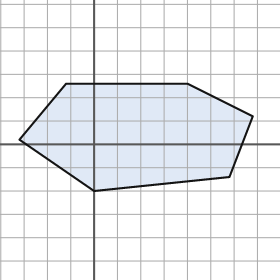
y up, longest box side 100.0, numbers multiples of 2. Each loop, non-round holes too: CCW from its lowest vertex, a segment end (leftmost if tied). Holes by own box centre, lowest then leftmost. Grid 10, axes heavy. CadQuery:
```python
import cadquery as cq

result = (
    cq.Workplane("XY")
    .moveTo(0.0, -20.0)
    .lineTo(58.0, -14.0)
    .lineTo(68.0, 12.0)
    .lineTo(40.0, 26.0)
    .lineTo(-12.0, 26.0)
    .lineTo(-32.0, 2.0)
    .close()
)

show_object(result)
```